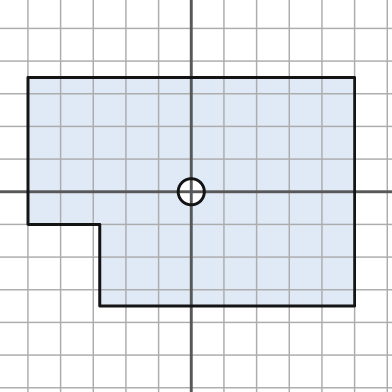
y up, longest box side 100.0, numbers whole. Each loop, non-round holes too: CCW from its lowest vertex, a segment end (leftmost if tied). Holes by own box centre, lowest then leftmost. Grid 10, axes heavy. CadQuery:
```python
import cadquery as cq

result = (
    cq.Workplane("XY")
    .moveTo(-28.0, -35.0)
    .lineTo(50.0, -35.0)
    .lineTo(50.0, 35.0)
    .lineTo(-50.0, 35.0)
    .lineTo(-50.0, -10.0)
    .lineTo(-28.0, -10.0)
    .close()
    .moveTo(0.0, 0.0)
    .circle(4.0)
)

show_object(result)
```